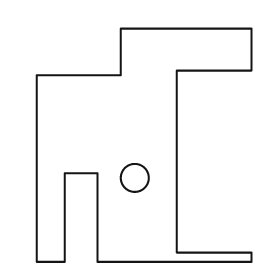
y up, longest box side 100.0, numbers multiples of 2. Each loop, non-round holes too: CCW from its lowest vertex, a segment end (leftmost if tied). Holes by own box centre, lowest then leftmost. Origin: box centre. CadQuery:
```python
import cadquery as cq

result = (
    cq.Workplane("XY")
    .moveTo(-46.0, -50.0)
    .lineTo(-34.0, -50.0)
    .lineTo(-34.0, -12.0)
    .lineTo(-20.0, -12.0)
    .lineTo(-20.0, -50.0)
    .lineTo(46.0, -50.0)
    .lineTo(46.0, -46.0)
    .lineTo(14.0, -46.0)
    .lineTo(14.0, 32.0)
    .lineTo(46.0, 32.0)
    .lineTo(46.0, 50.0)
    .lineTo(-10.0, 50.0)
    .lineTo(-10.0, 30.0)
    .lineTo(-46.0, 30.0)
    .close()
    .moveTo(-4.0, -14.0)
    .circle(6.0)
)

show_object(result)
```